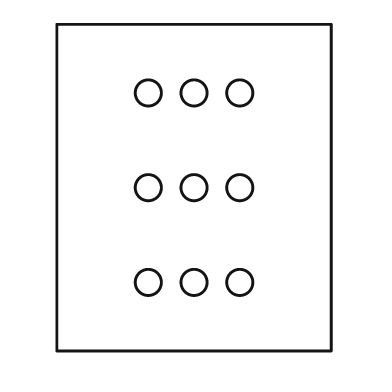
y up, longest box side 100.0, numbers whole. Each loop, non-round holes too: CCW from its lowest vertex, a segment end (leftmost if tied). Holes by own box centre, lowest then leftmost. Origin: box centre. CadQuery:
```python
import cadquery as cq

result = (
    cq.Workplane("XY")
    .moveTo(-42.0, -50.0)
    .lineTo(42.0, -50.0)
    .lineTo(42.0, 50.0)
    .lineTo(-42.0, 50.0)
    .close()
    .moveTo(-14.0, -29.0)
    .circle(4.0)
    .moveTo(0.0, -29.0)
    .circle(4.0)
    .moveTo(14.0, -29.0)
    .circle(4.0)
    .moveTo(-14.0, 0.0)
    .circle(4.0)
    .moveTo(0.0, 0.0)
    .circle(4.0)
    .moveTo(14.0, 0.0)
    .circle(4.0)
    .moveTo(-14.0, 29.0)
    .circle(4.0)
    .moveTo(0.0, 29.0)
    .circle(4.0)
    .moveTo(14.0, 29.0)
    .circle(4.0)
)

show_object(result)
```